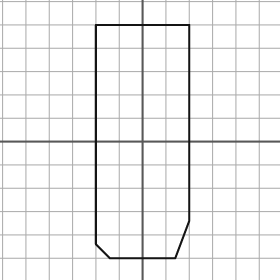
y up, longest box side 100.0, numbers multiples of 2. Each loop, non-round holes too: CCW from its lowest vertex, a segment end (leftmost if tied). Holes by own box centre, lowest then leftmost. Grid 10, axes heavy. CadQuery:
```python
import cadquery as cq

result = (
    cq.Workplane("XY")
    .moveTo(-14.0, -50.0)
    .lineTo(14.0, -50.0)
    .lineTo(20.0, -34.0)
    .lineTo(20.0, 50.0)
    .lineTo(-20.0, 50.0)
    .lineTo(-20.0, -44.0)
    .close()
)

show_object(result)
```